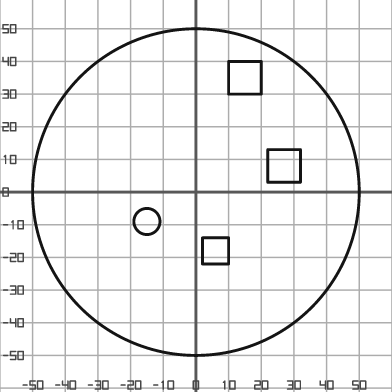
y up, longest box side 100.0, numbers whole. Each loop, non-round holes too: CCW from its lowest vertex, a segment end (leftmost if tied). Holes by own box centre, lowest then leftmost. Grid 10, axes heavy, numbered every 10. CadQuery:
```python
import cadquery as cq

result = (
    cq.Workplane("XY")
    .moveTo(0.0, 0.0)
    .circle(50.0)
    .moveTo(2.0, -22.0)
    .lineTo(10.0, -22.0)
    .lineTo(10.0, -14.0)
    .lineTo(2.0, -14.0)
    .close()
    .moveTo(-15.0, -9.0)
    .circle(4.0)
    .moveTo(22.0, 3.0)
    .lineTo(32.0, 3.0)
    .lineTo(32.0, 13.0)
    .lineTo(22.0, 13.0)
    .close()
    .moveTo(10.0, 30.0)
    .lineTo(20.0, 30.0)
    .lineTo(20.0, 40.0)
    .lineTo(10.0, 40.0)
    .close()
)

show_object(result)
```